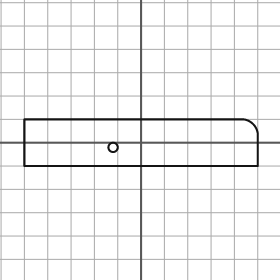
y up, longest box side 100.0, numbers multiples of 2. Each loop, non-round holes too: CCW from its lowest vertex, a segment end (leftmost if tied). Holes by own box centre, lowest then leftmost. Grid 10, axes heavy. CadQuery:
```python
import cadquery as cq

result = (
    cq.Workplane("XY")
    .moveTo(-50.0, -10.0)
    .lineTo(50.0, -10.0)
    .lineTo(50.0, 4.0)
    .threePointArc((48.0, 8.0), (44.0, 10.0))
    .lineTo(-50.0, 10.0)
    .close()
    .moveTo(-12.0, -2.0)
    .circle(2.0)
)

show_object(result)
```